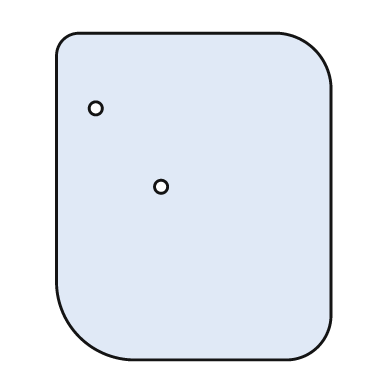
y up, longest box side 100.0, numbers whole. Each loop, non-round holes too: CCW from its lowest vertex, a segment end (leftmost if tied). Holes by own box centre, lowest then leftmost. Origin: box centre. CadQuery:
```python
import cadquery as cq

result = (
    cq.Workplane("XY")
    .moveTo(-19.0, -50.0)
    .lineTo(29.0, -50.0)
    .threePointArc((38.0, -46.0), (42.0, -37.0))
    .lineTo(42.0, 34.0)
    .threePointArc((37.0, 45.0), (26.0, 50.0))
    .lineTo(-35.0, 50.0)
    .threePointArc((-40.0, 48.0), (-42.0, 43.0))
    .lineTo(-42.0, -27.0)
    .threePointArc((-35.0, -43.0), (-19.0, -50.0))
    .close()
    .moveTo(-10.0, 3.0)
    .circle(2.0)
    .moveTo(-30.0, 27.0)
    .circle(2.0)
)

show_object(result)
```